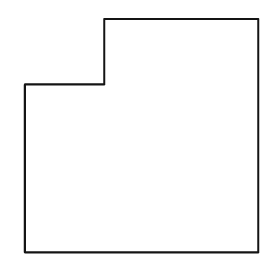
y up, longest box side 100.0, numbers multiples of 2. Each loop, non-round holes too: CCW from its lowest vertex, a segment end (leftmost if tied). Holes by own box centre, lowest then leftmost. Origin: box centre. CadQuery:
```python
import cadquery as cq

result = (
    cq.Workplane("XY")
    .moveTo(-50.0, -50.0)
    .lineTo(50.0, -50.0)
    .lineTo(50.0, 50.0)
    .lineTo(-16.0, 50.0)
    .lineTo(-16.0, 22.0)
    .lineTo(-50.0, 22.0)
    .close()
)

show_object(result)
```